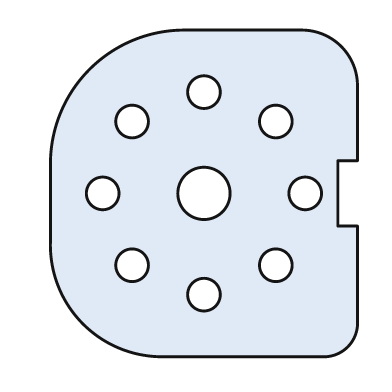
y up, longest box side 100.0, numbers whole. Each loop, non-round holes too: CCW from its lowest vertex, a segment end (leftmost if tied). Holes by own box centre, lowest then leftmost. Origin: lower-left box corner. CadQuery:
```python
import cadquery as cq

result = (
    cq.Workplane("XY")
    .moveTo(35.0, 0.0)
    .lineTo(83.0, 0.0)
    .threePointArc((91.0, 3.0), (94.0, 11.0))
    .lineTo(94.0, 40.0)
    .lineTo(88.0, 40.0)
    .lineTo(88.0, 60.0)
    .lineTo(94.0, 60.0)
    .lineTo(94.0, 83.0)
    .threePointArc((89.0, 95.0), (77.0, 100.0))
    .lineTo(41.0, 100.0)
    .threePointArc((12.0, 88.0), (0.0, 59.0))
    .lineTo(0.0, 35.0)
    .threePointArc((10.0, 10.0), (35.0, 0.0))
    .close()
    .moveTo(47.0, 19.0)
    .circle(5.0)
    .moveTo(25.0, 28.0)
    .circle(5.0)
    .moveTo(69.0, 28.0)
    .circle(5.0)
    .moveTo(16.0, 50.0)
    .circle(5.0)
    .moveTo(47.0, 50.0)
    .circle(8.0)
    .moveTo(78.0, 50.0)
    .circle(5.0)
    .moveTo(25.0, 72.0)
    .circle(5.0)
    .moveTo(69.0, 72.0)
    .circle(5.0)
    .moveTo(47.0, 81.0)
    .circle(5.0)
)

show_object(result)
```